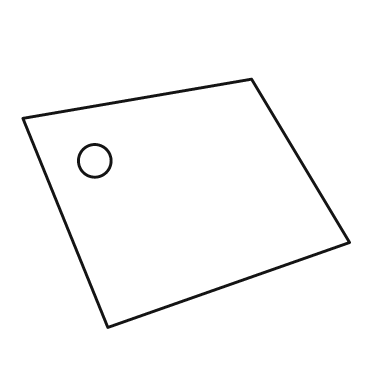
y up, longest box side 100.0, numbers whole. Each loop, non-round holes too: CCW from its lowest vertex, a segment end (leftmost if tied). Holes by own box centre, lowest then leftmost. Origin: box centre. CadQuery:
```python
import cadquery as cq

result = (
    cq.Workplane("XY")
    .moveTo(-24.0, -38.0)
    .lineTo(50.0, -12.0)
    .lineTo(20.0, 38.0)
    .lineTo(-50.0, 26.0)
    .close()
    .moveTo(-28.0, 13.0)
    .circle(5.0)
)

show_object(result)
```